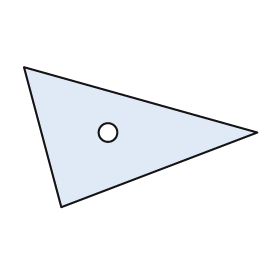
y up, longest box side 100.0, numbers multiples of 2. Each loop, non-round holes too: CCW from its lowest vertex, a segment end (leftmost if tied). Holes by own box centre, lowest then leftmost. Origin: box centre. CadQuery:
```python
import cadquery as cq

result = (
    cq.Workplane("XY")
    .moveTo(-34.0, -30.0)
    .lineTo(50.0, 2.0)
    .lineTo(-50.0, 30.0)
    .close()
    .moveTo(-14.0, 2.0)
    .circle(4.0)
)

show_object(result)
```